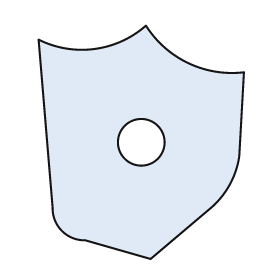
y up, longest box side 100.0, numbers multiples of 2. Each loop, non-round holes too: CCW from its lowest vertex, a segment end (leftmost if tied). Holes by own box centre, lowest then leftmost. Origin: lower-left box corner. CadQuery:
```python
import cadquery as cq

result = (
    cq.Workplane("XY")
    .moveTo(48.0, 0.0)
    .lineTo(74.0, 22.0)
    .threePointArc((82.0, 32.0), (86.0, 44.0))
    .lineTo(88.0, 80.0)
    .threePointArc((64.0, 84.0), (46.0, 100.0))
    .threePointArc((24.0, 90.0), (0.0, 94.0))
    .lineTo(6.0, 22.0)
    .threePointArc((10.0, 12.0), (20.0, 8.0))
    .close()
    .moveTo(44.0, 50.0)
    .circle(10.0)
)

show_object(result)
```